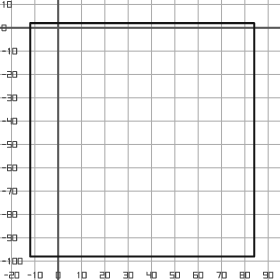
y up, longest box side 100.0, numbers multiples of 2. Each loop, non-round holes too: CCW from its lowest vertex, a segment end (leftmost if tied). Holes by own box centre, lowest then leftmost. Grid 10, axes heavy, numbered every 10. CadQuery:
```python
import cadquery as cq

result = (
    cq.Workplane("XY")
    .moveTo(-12.0, -98.0)
    .lineTo(84.0, -98.0)
    .lineTo(84.0, 2.0)
    .lineTo(-12.0, 2.0)
    .close()
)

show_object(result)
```